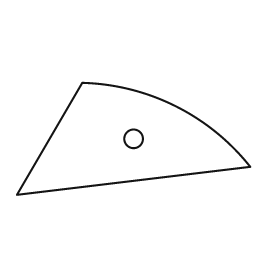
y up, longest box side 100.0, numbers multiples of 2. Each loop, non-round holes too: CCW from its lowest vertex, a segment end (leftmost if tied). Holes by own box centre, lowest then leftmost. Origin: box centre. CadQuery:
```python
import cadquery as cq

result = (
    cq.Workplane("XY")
    .moveTo(-50.0, -24.0)
    .lineTo(50.0, -12.0)
    .threePointArc((18.0, 14.0), (-22.0, 24.0))
    .close()
    .moveTo(0.0, 0.0)
    .circle(4.0)
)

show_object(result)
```